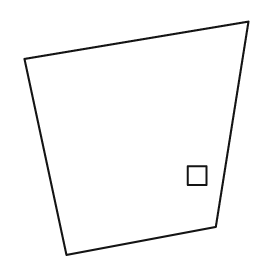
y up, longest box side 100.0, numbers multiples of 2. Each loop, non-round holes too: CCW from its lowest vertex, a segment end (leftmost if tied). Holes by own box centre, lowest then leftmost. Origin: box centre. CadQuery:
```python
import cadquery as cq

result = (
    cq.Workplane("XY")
    .moveTo(-30.0, -50.0)
    .lineTo(34.0, -38.0)
    .lineTo(48.0, 50.0)
    .lineTo(-48.0, 34.0)
    .close()
    .moveTo(22.0, -20.0)
    .lineTo(30.0, -20.0)
    .lineTo(30.0, -12.0)
    .lineTo(22.0, -12.0)
    .close()
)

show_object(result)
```